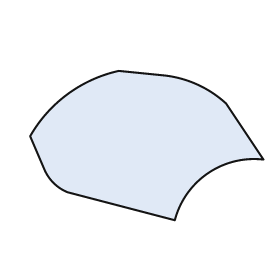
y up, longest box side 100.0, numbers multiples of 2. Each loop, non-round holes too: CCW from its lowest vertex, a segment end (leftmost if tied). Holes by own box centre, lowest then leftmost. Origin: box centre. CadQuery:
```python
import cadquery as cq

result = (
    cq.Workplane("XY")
    .moveTo(12.0, -32.0)
    .threePointArc((26.0, -12.0), (50.0, -6.0))
    .lineTo(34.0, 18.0)
    .threePointArc((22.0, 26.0), (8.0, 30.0))
    .lineTo(-12.0, 32.0)
    .threePointArc((-34.0, 22.0), (-50.0, 4.0))
    .lineTo(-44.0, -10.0)
    .threePointArc((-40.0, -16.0), (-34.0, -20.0))
    .close()
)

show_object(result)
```